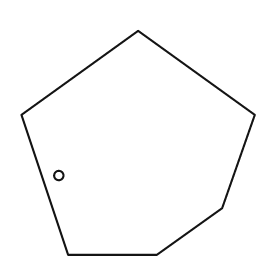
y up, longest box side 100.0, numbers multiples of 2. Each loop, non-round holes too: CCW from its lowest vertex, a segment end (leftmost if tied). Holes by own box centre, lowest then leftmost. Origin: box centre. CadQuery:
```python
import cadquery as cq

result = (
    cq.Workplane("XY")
    .moveTo(-30.0, -48.0)
    .lineTo(8.0, -48.0)
    .lineTo(36.0, -28.0)
    .lineTo(50.0, 12.0)
    .lineTo(0.0, 48.0)
    .lineTo(-50.0, 12.0)
    .close()
    .moveTo(-34.0, -14.0)
    .circle(2.0)
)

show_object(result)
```